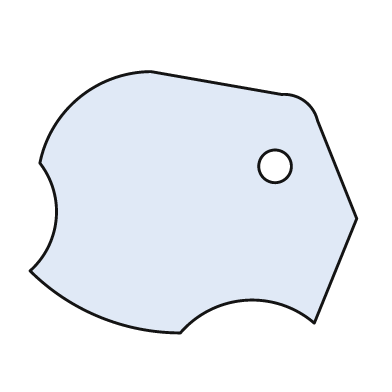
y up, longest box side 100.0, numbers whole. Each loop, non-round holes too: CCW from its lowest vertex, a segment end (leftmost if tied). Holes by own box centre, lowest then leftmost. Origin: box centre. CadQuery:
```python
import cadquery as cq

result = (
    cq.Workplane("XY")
    .moveTo(-4.0, -40.0)
    .threePointArc((16.0, -30.0), (37.0, -37.0))
    .lineTo(50.0, -5.0)
    .lineTo(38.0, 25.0)
    .threePointArc((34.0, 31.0), (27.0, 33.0))
    .lineTo(-13.0, 40.0)
    .threePointArc((-35.0, 32.0), (-47.0, 12.0))
    .threePointArc((-42.0, -5.0), (-50.0, -21.0))
    .threePointArc((-29.0, -35.0), (-4.0, -40.0))
    .close()
    .moveTo(25.0, 11.0)
    .circle(5.0)
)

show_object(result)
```